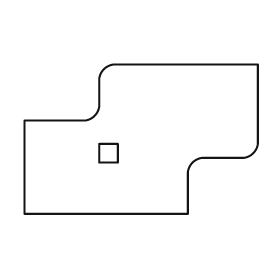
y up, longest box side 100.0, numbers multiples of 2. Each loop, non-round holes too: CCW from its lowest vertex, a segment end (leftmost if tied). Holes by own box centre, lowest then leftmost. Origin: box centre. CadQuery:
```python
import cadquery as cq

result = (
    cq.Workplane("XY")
    .moveTo(-50.0, -32.0)
    .lineTo(20.0, -32.0)
    .lineTo(20.0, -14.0)
    .threePointArc((22.0, -10.0), (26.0, -8.0))
    .lineTo(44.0, -8.0)
    .threePointArc((48.0, -6.0), (50.0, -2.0))
    .lineTo(50.0, 32.0)
    .lineTo(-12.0, 32.0)
    .threePointArc((-16.0, 30.0), (-18.0, 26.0))
    .lineTo(-18.0, 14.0)
    .threePointArc((-20.0, 10.0), (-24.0, 8.0))
    .lineTo(-50.0, 8.0)
    .close()
    .moveTo(-18.0, -10.0)
    .lineTo(-10.0, -10.0)
    .lineTo(-10.0, -2.0)
    .lineTo(-18.0, -2.0)
    .close()
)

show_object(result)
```